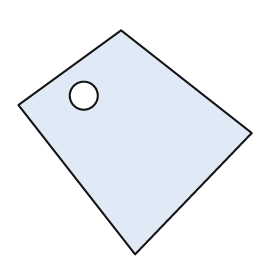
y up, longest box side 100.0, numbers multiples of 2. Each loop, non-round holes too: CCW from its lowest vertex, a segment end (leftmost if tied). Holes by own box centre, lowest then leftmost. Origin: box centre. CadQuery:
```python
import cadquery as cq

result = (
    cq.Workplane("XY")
    .moveTo(0.0, -48.0)
    .lineTo(50.0, 4.0)
    .lineTo(-6.0, 48.0)
    .lineTo(-50.0, 16.0)
    .close()
    .moveTo(-22.0, 20.0)
    .circle(6.0)
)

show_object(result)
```